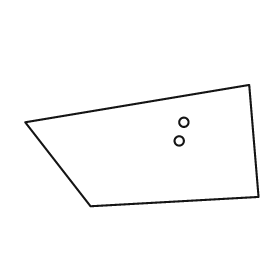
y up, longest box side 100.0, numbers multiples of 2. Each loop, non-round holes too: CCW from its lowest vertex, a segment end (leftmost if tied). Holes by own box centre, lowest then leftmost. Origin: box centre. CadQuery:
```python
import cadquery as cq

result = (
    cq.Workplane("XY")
    .moveTo(-22.0, -26.0)
    .lineTo(50.0, -22.0)
    .lineTo(46.0, 26.0)
    .lineTo(-50.0, 10.0)
    .close()
    .moveTo(16.0, 2.0)
    .circle(2.0)
    .moveTo(18.0, 10.0)
    .circle(2.0)
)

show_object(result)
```